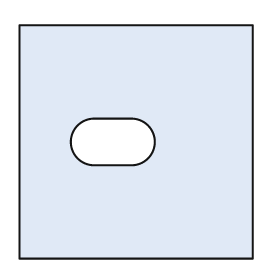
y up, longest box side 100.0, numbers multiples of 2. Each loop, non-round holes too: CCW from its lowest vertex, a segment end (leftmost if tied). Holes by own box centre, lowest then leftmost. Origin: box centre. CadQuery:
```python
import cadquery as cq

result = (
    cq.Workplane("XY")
    .moveTo(-50.0, -50.0)
    .lineTo(50.0, -50.0)
    .lineTo(50.0, 50.0)
    .lineTo(-50.0, 50.0)
    .close()
    .moveTo(-18.0, -10.0)
    .lineTo(-2.0, -10.0)
    .threePointArc((8.0, 0.0), (-2.0, 10.0))
    .lineTo(-18.0, 10.0)
    .threePointArc((-28.0, 0.0), (-18.0, -10.0))
    .close()
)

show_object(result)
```